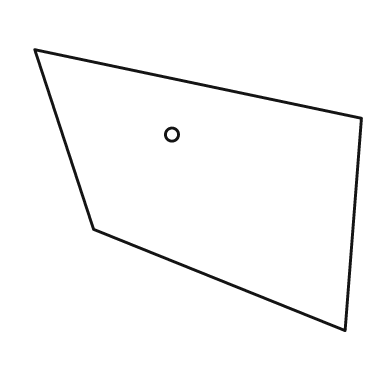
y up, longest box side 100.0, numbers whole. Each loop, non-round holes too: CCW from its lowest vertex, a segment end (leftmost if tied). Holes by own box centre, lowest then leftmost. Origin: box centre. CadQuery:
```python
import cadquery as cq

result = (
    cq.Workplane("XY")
    .moveTo(45.0, -43.0)
    .lineTo(50.0, 22.0)
    .lineTo(-50.0, 43.0)
    .lineTo(-32.0, -12.0)
    .close()
    .moveTo(-8.0, 17.0)
    .circle(2.0)
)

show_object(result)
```